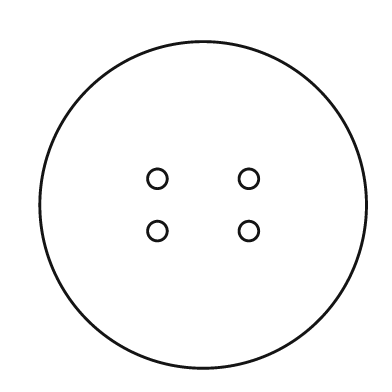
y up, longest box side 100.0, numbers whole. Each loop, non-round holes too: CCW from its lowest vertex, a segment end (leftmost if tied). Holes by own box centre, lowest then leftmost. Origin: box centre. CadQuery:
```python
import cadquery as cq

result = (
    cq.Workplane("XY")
    .moveTo(0.0, 0.0)
    .circle(50.0)
    .moveTo(-14.0, -8.0)
    .circle(3.0)
    .moveTo(14.0, -8.0)
    .circle(3.0)
    .moveTo(-14.0, 8.0)
    .circle(3.0)
    .moveTo(14.0, 8.0)
    .circle(3.0)
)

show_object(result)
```